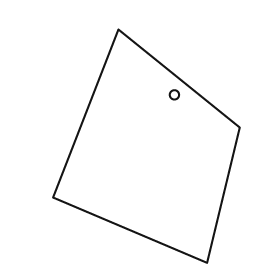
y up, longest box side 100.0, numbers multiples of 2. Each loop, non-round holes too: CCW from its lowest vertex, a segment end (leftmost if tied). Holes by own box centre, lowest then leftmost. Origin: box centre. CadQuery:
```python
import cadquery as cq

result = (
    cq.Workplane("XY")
    .moveTo(26.0, -50.0)
    .lineTo(40.0, 8.0)
    .lineTo(-12.0, 50.0)
    .lineTo(-40.0, -22.0)
    .close()
    .moveTo(12.0, 22.0)
    .circle(2.0)
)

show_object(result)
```